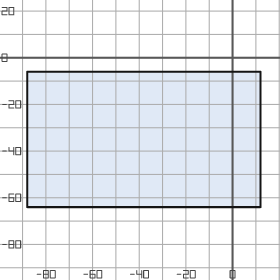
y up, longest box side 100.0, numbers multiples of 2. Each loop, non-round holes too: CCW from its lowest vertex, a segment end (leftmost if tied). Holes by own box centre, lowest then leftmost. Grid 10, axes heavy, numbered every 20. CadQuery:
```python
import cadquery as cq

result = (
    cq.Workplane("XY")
    .moveTo(-88.0, -64.0)
    .lineTo(12.0, -64.0)
    .lineTo(12.0, -6.0)
    .lineTo(-88.0, -6.0)
    .close()
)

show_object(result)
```